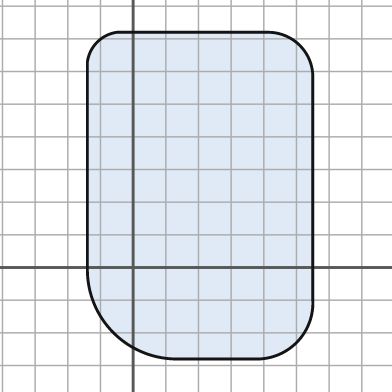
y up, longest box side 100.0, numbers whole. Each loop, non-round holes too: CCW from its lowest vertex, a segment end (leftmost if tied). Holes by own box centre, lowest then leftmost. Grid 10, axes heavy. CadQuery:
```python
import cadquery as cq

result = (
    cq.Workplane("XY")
    .moveTo(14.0, -28.0)
    .lineTo(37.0, -28.0)
    .threePointArc((50.0, -23.0), (55.0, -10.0))
    .lineTo(55.0, 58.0)
    .threePointArc((51.0, 68.0), (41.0, 72.0))
    .lineTo(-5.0, 72.0)
    .threePointArc((-11.0, 69.0), (-14.0, 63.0))
    .lineTo(-14.0, 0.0)
    .threePointArc((-6.0, -20.0), (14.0, -28.0))
    .close()
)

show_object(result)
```